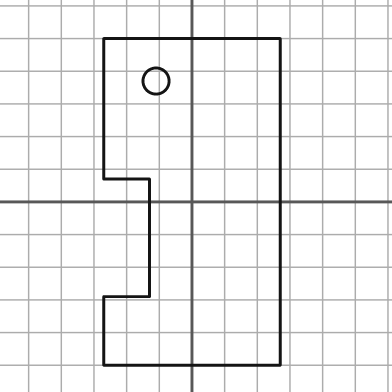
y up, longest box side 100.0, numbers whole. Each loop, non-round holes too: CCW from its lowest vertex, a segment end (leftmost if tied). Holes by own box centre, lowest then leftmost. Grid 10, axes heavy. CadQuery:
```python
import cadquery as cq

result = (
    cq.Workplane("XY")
    .moveTo(-27.0, -50.0)
    .lineTo(27.0, -50.0)
    .lineTo(27.0, 50.0)
    .lineTo(-27.0, 50.0)
    .lineTo(-27.0, 7.0)
    .lineTo(-13.0, 7.0)
    .lineTo(-13.0, -29.0)
    .lineTo(-27.0, -29.0)
    .close()
    .moveTo(-11.0, 37.0)
    .circle(4.0)
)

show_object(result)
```